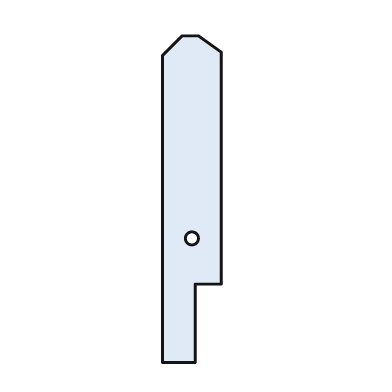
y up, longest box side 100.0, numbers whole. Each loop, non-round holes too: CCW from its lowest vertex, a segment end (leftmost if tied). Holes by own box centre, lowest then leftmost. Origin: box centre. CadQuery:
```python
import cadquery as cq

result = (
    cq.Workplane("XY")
    .moveTo(-9.0, -50.0)
    .lineTo(1.0, -50.0)
    .lineTo(1.0, -26.0)
    .lineTo(9.0, -26.0)
    .lineTo(9.0, 45.0)
    .lineTo(2.0, 50.0)
    .lineTo(-3.0, 50.0)
    .lineTo(-9.0, 44.0)
    .close()
    .moveTo(0.0, -12.0)
    .circle(2.0)
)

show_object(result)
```